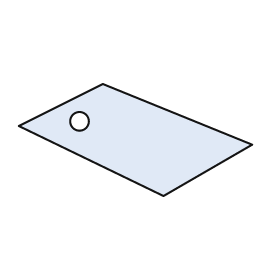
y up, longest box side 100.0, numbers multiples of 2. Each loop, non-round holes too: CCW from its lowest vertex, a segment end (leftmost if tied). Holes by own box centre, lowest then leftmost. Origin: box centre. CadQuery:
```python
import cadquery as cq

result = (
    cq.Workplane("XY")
    .moveTo(12.0, -24.0)
    .lineTo(50.0, -2.0)
    .lineTo(-14.0, 24.0)
    .lineTo(-50.0, 6.0)
    .close()
    .moveTo(-24.0, 8.0)
    .circle(4.0)
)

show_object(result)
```